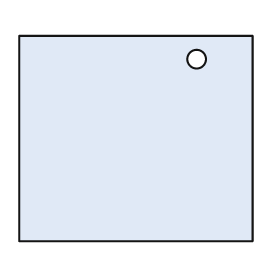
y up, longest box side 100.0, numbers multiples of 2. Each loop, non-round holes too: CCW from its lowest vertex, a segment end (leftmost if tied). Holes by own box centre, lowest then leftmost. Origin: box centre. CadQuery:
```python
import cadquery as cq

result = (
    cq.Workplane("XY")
    .moveTo(-50.0, -44.0)
    .lineTo(50.0, -44.0)
    .lineTo(50.0, 44.0)
    .lineTo(-50.0, 44.0)
    .close()
    .moveTo(26.0, 34.0)
    .circle(4.0)
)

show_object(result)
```